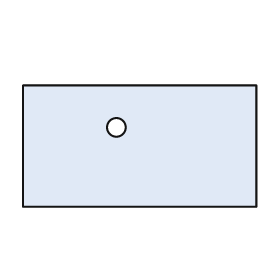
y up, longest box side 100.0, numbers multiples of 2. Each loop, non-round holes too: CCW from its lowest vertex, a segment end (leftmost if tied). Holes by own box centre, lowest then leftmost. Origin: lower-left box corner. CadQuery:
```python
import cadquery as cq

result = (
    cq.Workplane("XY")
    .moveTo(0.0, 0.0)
    .lineTo(100.0, 0.0)
    .lineTo(100.0, 52.0)
    .lineTo(0.0, 52.0)
    .close()
    .moveTo(40.0, 34.0)
    .circle(4.0)
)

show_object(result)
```